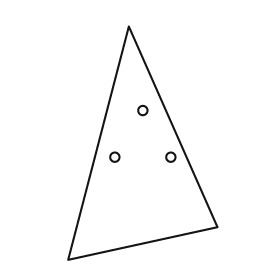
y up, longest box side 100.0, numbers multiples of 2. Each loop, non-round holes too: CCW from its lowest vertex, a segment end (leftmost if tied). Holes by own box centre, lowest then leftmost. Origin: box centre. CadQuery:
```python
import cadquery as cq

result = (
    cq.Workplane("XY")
    .moveTo(-32.0, -50.0)
    .lineTo(32.0, -36.0)
    .lineTo(-6.0, 50.0)
    .close()
    .moveTo(-12.0, -6.0)
    .circle(2.0)
    .moveTo(12.0, -6.0)
    .circle(2.0)
    .moveTo(0.0, 14.0)
    .circle(2.0)
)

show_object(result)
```